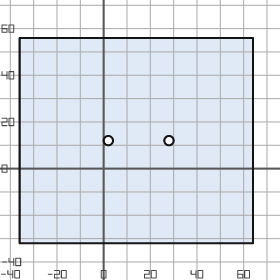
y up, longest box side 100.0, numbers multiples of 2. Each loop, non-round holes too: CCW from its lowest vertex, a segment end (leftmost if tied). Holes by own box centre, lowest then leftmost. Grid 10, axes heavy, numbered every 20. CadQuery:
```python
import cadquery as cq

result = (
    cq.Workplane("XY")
    .moveTo(-36.0, -32.0)
    .lineTo(64.0, -32.0)
    .lineTo(64.0, 56.0)
    .lineTo(-36.0, 56.0)
    .close()
    .moveTo(2.0, 12.0)
    .circle(2.0)
    .moveTo(28.0, 12.0)
    .circle(2.0)
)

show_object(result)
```